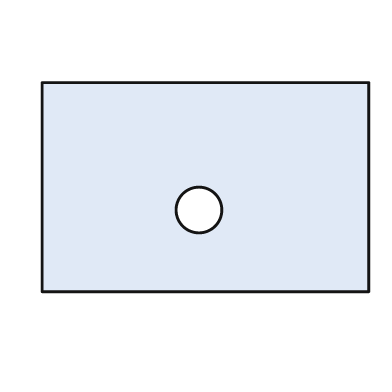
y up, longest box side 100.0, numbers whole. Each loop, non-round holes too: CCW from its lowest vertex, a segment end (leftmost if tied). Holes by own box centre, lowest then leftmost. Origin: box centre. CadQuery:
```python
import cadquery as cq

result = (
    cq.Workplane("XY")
    .moveTo(-50.0, -32.0)
    .lineTo(50.0, -32.0)
    .lineTo(50.0, 32.0)
    .lineTo(-50.0, 32.0)
    .close()
    .moveTo(-2.0, -7.0)
    .circle(7.0)
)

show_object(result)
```